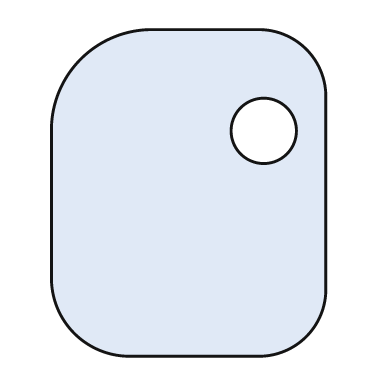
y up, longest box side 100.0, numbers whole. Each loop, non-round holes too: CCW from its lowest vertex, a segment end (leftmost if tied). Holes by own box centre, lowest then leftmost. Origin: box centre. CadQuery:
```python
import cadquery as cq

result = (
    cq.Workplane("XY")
    .moveTo(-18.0, -50.0)
    .lineTo(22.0, -50.0)
    .threePointArc((36.0, -44.0), (42.0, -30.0))
    .lineTo(42.0, 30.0)
    .threePointArc((36.0, 44.0), (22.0, 50.0))
    .lineTo(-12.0, 50.0)
    .threePointArc((-33.0, 41.0), (-42.0, 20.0))
    .lineTo(-42.0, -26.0)
    .threePointArc((-35.0, -43.0), (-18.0, -50.0))
    .close()
    .moveTo(23.0, 19.0)
    .circle(10.0)
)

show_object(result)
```